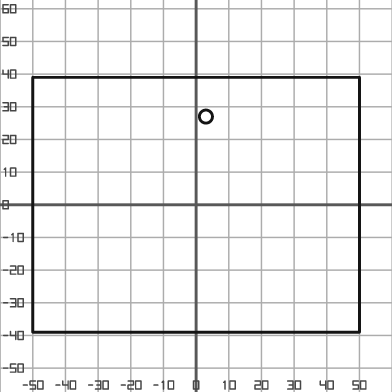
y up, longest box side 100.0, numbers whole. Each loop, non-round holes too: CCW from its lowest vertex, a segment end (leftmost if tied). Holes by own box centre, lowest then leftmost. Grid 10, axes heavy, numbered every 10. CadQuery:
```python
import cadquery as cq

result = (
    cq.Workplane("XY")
    .moveTo(-50.0, -39.0)
    .lineTo(50.0, -39.0)
    .lineTo(50.0, 39.0)
    .lineTo(-50.0, 39.0)
    .close()
    .moveTo(3.0, 27.0)
    .circle(2.0)
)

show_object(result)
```